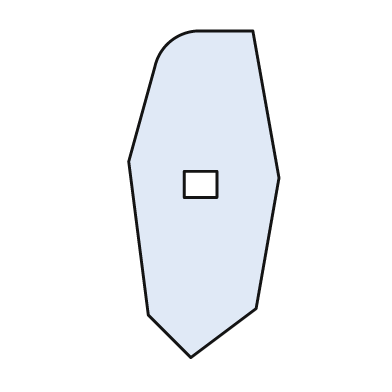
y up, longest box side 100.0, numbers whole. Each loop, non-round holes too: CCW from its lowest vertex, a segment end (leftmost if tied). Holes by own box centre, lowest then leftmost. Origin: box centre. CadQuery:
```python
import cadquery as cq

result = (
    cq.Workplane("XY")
    .moveTo(-4.0, -50.0)
    .lineTo(16.0, -35.0)
    .lineTo(23.0, 5.0)
    .lineTo(15.0, 50.0)
    .lineTo(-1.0, 50.0)
    .threePointArc((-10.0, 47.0), (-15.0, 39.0))
    .lineTo(-23.0, 10.0)
    .lineTo(-17.0, -37.0)
    .close()
    .moveTo(-6.0, -1.0)
    .lineTo(4.0, -1.0)
    .lineTo(4.0, 7.0)
    .lineTo(-6.0, 7.0)
    .close()
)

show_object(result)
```